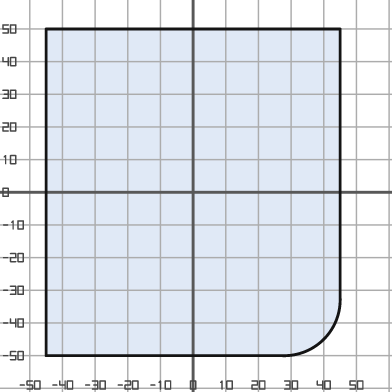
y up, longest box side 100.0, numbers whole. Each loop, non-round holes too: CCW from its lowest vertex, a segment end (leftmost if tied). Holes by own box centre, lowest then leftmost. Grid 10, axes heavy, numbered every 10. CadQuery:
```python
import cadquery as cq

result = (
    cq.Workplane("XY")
    .moveTo(-45.0, -50.0)
    .lineTo(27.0, -50.0)
    .threePointArc((40.0, -45.0), (45.0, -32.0))
    .lineTo(45.0, 50.0)
    .lineTo(-45.0, 50.0)
    .close()
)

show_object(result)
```